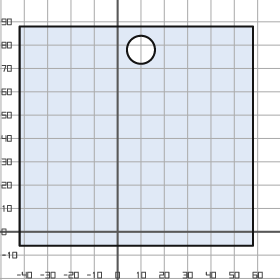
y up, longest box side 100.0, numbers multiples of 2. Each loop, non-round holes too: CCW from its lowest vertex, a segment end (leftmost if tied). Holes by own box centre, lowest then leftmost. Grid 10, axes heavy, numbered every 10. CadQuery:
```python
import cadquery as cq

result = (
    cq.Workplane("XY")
    .moveTo(-42.0, -6.0)
    .lineTo(58.0, -6.0)
    .lineTo(58.0, 88.0)
    .lineTo(-42.0, 88.0)
    .close()
    .moveTo(10.0, 78.0)
    .circle(6.0)
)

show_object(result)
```